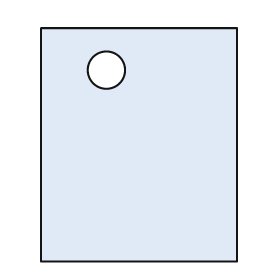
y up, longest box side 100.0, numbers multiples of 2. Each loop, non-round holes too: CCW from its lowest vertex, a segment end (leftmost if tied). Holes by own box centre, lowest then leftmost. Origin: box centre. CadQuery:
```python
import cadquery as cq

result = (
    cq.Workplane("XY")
    .moveTo(-42.0, -50.0)
    .lineTo(42.0, -50.0)
    .lineTo(42.0, 50.0)
    .lineTo(-42.0, 50.0)
    .close()
    .moveTo(-14.0, 32.0)
    .circle(8.0)
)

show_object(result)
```